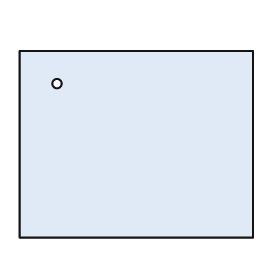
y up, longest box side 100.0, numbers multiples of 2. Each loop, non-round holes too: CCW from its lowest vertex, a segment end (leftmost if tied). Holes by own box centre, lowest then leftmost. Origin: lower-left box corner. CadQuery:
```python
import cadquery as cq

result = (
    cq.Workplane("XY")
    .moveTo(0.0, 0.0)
    .lineTo(100.0, 0.0)
    .lineTo(100.0, 80.0)
    .lineTo(0.0, 80.0)
    .close()
    .moveTo(16.0, 66.0)
    .circle(2.0)
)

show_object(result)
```